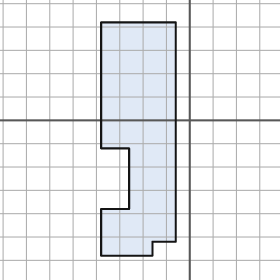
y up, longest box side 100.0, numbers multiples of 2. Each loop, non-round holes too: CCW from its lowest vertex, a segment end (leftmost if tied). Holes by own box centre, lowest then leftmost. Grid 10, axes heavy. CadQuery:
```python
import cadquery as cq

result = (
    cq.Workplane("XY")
    .moveTo(-38.0, -58.0)
    .lineTo(-16.0, -58.0)
    .lineTo(-16.0, -52.0)
    .lineTo(-6.0, -52.0)
    .lineTo(-6.0, 42.0)
    .lineTo(-38.0, 42.0)
    .lineTo(-38.0, -12.0)
    .lineTo(-26.0, -12.0)
    .lineTo(-26.0, -38.0)
    .lineTo(-38.0, -38.0)
    .close()
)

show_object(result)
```